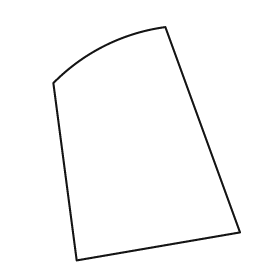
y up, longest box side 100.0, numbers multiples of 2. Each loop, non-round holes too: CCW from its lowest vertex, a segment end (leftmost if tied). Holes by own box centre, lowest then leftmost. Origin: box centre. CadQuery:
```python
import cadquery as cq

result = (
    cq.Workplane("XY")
    .moveTo(-30.0, -50.0)
    .lineTo(40.0, -38.0)
    .lineTo(8.0, 50.0)
    .threePointArc((-18.0, 42.0), (-40.0, 26.0))
    .close()
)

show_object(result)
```